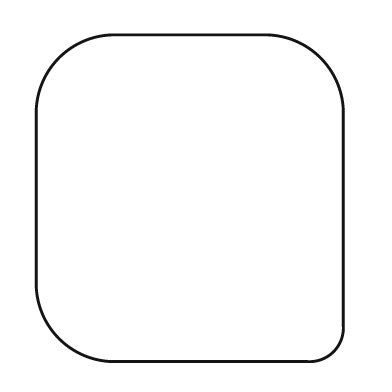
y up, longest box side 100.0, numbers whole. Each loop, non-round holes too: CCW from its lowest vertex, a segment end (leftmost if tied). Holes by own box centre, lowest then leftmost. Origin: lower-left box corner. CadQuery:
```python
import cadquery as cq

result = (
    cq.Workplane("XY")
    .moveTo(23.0, 0.0)
    .lineTo(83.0, 0.0)
    .threePointArc((91.0, 3.0), (94.0, 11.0))
    .lineTo(94.0, 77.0)
    .threePointArc((87.0, 93.0), (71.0, 100.0))
    .lineTo(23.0, 100.0)
    .threePointArc((7.0, 93.0), (0.0, 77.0))
    .lineTo(0.0, 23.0)
    .threePointArc((7.0, 7.0), (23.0, 0.0))
    .close()
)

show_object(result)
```